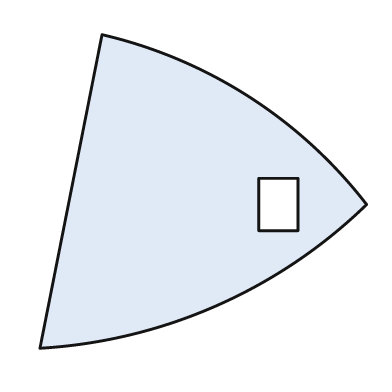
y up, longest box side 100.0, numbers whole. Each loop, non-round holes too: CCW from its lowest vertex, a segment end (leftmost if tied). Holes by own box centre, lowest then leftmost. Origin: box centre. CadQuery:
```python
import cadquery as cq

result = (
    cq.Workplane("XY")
    .moveTo(-50.0, -48.0)
    .threePointArc((4.0, -35.0), (50.0, -4.0))
    .threePointArc((14.0, 29.0), (-31.0, 48.0))
    .close()
    .moveTo(17.0, -12.0)
    .lineTo(29.0, -12.0)
    .lineTo(29.0, 4.0)
    .lineTo(17.0, 4.0)
    .close()
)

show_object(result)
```